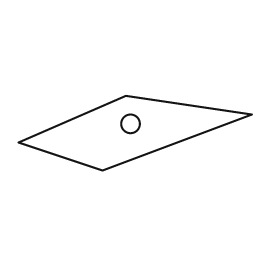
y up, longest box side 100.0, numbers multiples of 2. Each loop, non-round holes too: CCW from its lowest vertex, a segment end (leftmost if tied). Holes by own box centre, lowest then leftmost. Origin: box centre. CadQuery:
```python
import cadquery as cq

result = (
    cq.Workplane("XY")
    .moveTo(-14.0, -16.0)
    .lineTo(50.0, 8.0)
    .lineTo(-4.0, 16.0)
    .lineTo(-50.0, -4.0)
    .close()
    .moveTo(-2.0, 4.0)
    .circle(4.0)
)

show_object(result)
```